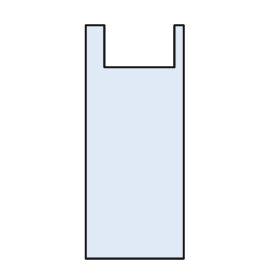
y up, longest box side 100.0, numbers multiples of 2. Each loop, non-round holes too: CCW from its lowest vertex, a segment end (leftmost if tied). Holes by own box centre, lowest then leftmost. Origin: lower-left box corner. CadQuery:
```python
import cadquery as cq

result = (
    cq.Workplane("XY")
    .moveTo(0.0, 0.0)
    .lineTo(42.0, 0.0)
    .lineTo(42.0, 100.0)
    .lineTo(38.0, 100.0)
    .lineTo(38.0, 82.0)
    .lineTo(8.0, 82.0)
    .lineTo(8.0, 100.0)
    .lineTo(0.0, 100.0)
    .close()
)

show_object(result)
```